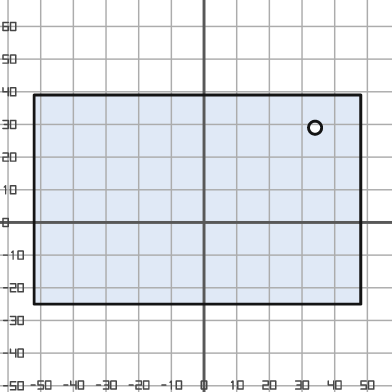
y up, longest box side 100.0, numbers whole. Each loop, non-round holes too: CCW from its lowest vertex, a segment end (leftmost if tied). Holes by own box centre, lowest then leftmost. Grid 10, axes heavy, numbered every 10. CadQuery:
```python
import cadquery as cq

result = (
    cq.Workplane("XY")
    .moveTo(-52.0, -25.0)
    .lineTo(48.0, -25.0)
    .lineTo(48.0, 39.0)
    .lineTo(-52.0, 39.0)
    .close()
    .moveTo(34.0, 29.0)
    .circle(2.0)
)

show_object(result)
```